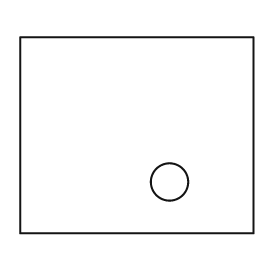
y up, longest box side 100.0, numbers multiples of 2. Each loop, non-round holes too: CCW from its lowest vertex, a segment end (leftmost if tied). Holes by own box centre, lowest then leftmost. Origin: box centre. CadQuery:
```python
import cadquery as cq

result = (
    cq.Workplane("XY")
    .moveTo(-50.0, -42.0)
    .lineTo(50.0, -42.0)
    .lineTo(50.0, 42.0)
    .lineTo(-50.0, 42.0)
    .close()
    .moveTo(14.0, -20.0)
    .circle(8.0)
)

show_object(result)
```